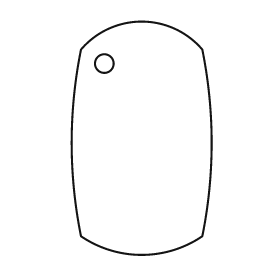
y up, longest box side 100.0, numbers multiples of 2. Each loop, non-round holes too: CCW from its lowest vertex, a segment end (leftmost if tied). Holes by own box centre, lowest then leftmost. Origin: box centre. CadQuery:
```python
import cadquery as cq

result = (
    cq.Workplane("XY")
    .moveTo(-26.0, -42.0)
    .threePointArc((0.0, -50.0), (26.0, -42.0))
    .threePointArc((30.0, -2.0), (26.0, 38.0))
    .threePointArc((0.0, 50.0), (-26.0, 38.0))
    .threePointArc((-30.0, -2.0), (-26.0, -42.0))
    .close()
    .moveTo(-16.0, 32.0)
    .circle(4.0)
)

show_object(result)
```